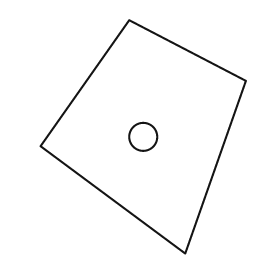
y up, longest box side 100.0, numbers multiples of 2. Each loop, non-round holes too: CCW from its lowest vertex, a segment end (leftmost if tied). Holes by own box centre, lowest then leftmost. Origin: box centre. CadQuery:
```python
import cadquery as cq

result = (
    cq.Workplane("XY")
    .moveTo(18.0, -50.0)
    .lineTo(44.0, 24.0)
    .lineTo(-6.0, 50.0)
    .lineTo(-44.0, -4.0)
    .close()
    .moveTo(0.0, 0.0)
    .circle(6.0)
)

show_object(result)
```